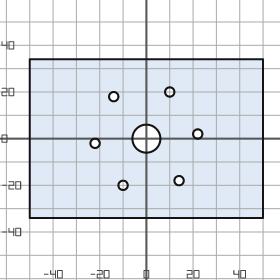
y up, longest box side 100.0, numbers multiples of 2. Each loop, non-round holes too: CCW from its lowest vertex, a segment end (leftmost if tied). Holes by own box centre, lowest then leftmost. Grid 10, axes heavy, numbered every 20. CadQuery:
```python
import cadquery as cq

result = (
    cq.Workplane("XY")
    .moveTo(-50.0, -34.0)
    .lineTo(50.0, -34.0)
    .lineTo(50.0, 34.0)
    .lineTo(-50.0, 34.0)
    .close()
    .moveTo(-10.0, -20.0)
    .circle(2.0)
    .moveTo(14.0, -18.0)
    .circle(2.0)
    .moveTo(-22.0, -2.0)
    .circle(2.0)
    .moveTo(0.0, 0.0)
    .circle(6.0)
    .moveTo(22.0, 2.0)
    .circle(2.0)
    .moveTo(-14.0, 18.0)
    .circle(2.0)
    .moveTo(10.0, 20.0)
    .circle(2.0)
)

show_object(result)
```